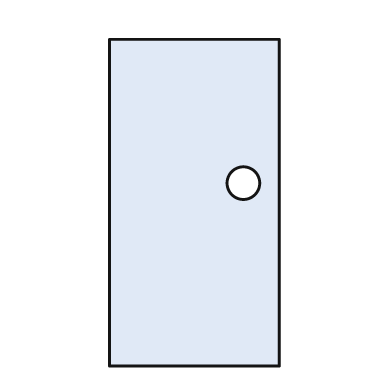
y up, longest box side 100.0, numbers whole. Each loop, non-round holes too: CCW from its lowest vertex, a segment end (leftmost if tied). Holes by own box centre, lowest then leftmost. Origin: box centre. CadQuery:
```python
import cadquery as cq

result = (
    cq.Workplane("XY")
    .moveTo(-26.0, -50.0)
    .lineTo(26.0, -50.0)
    .lineTo(26.0, 50.0)
    .lineTo(-26.0, 50.0)
    .close()
    .moveTo(15.0, 6.0)
    .circle(5.0)
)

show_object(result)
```